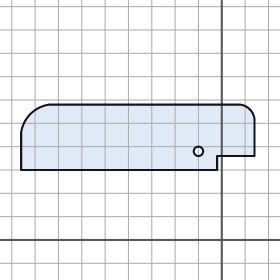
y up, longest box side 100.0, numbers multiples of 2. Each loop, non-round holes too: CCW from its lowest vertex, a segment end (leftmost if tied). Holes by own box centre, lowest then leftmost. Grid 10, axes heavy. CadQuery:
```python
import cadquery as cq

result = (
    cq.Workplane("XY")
    .moveTo(-86.0, 30.0)
    .lineTo(-2.0, 30.0)
    .lineTo(-2.0, 36.0)
    .lineTo(14.0, 36.0)
    .lineTo(14.0, 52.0)
    .threePointArc((12.0, 56.0), (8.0, 58.0))
    .lineTo(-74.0, 58.0)
    .threePointArc((-82.0, 54.0), (-86.0, 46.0))
    .close()
    .moveTo(-10.0, 38.0)
    .circle(2.0)
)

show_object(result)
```